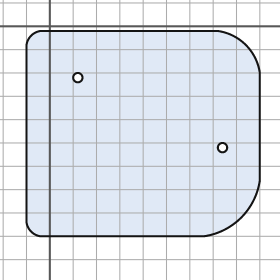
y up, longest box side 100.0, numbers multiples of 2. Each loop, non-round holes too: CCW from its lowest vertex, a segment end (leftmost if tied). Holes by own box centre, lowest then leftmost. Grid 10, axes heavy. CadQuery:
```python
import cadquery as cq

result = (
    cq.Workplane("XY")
    .moveTo(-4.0, -90.0)
    .lineTo(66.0, -90.0)
    .threePointArc((82.0, -82.0), (90.0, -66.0))
    .lineTo(90.0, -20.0)
    .threePointArc((84.0, -8.0), (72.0, -2.0))
    .lineTo(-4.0, -2.0)
    .threePointArc((-8.0, -4.0), (-10.0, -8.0))
    .lineTo(-10.0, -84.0)
    .threePointArc((-8.0, -88.0), (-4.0, -90.0))
    .close()
    .moveTo(74.0, -52.0)
    .circle(2.0)
    .moveTo(12.0, -22.0)
    .circle(2.0)
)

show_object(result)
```